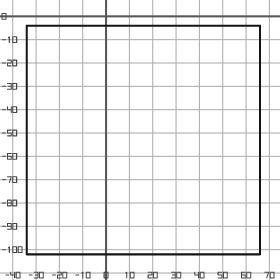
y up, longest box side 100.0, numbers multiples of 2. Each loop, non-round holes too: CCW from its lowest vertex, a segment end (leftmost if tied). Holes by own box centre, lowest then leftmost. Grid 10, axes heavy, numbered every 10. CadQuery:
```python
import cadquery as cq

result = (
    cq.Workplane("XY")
    .moveTo(-34.0, -102.0)
    .lineTo(66.0, -102.0)
    .lineTo(66.0, -4.0)
    .lineTo(-34.0, -4.0)
    .close()
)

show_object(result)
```